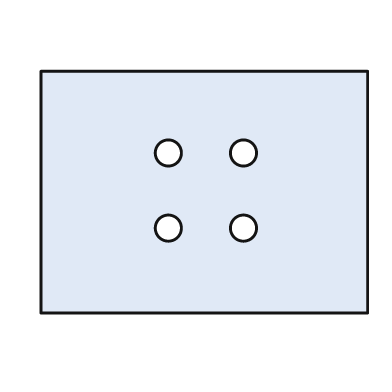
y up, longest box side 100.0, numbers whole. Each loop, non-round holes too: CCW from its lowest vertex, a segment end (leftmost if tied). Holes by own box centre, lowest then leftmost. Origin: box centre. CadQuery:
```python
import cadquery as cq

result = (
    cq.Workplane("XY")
    .moveTo(-50.0, -37.0)
    .lineTo(50.0, -37.0)
    .lineTo(50.0, 37.0)
    .lineTo(-50.0, 37.0)
    .close()
    .moveTo(-11.0, -11.0)
    .circle(4.0)
    .moveTo(12.0, -11.0)
    .circle(4.0)
    .moveTo(-11.0, 12.0)
    .circle(4.0)
    .moveTo(12.0, 12.0)
    .circle(4.0)
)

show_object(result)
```